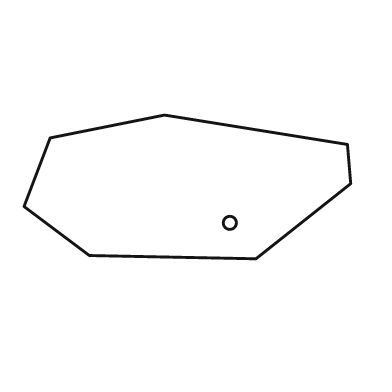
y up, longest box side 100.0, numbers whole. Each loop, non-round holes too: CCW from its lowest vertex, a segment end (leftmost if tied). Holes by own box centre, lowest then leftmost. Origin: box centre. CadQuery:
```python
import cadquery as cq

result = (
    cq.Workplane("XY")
    .moveTo(21.0, -22.0)
    .lineTo(50.0, 1.0)
    .lineTo(49.0, 13.0)
    .lineTo(-7.0, 22.0)
    .lineTo(-42.0, 15.0)
    .lineTo(-50.0, -6.0)
    .lineTo(-30.0, -21.0)
    .close()
    .moveTo(13.0, -11.0)
    .circle(2.0)
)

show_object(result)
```